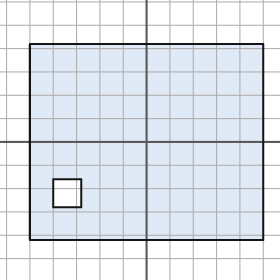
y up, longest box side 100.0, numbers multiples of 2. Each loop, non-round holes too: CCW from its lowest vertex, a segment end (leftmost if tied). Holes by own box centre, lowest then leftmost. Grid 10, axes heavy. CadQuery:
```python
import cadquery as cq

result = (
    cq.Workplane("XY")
    .moveTo(-50.0, -42.0)
    .lineTo(50.0, -42.0)
    .lineTo(50.0, 42.0)
    .lineTo(-50.0, 42.0)
    .close()
    .moveTo(-40.0, -28.0)
    .lineTo(-28.0, -28.0)
    .lineTo(-28.0, -16.0)
    .lineTo(-40.0, -16.0)
    .close()
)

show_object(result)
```